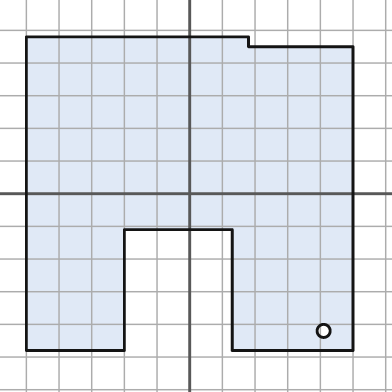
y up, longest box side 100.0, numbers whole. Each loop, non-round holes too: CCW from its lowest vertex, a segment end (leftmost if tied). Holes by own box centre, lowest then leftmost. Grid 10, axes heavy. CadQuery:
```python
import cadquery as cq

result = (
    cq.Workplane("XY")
    .moveTo(-50.0, -48.0)
    .lineTo(-20.0, -48.0)
    .lineTo(-20.0, -11.0)
    .lineTo(13.0, -11.0)
    .lineTo(13.0, -48.0)
    .lineTo(50.0, -48.0)
    .lineTo(50.0, 45.0)
    .lineTo(18.0, 45.0)
    .lineTo(18.0, 48.0)
    .lineTo(-50.0, 48.0)
    .close()
    .moveTo(41.0, -42.0)
    .circle(2.0)
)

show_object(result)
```